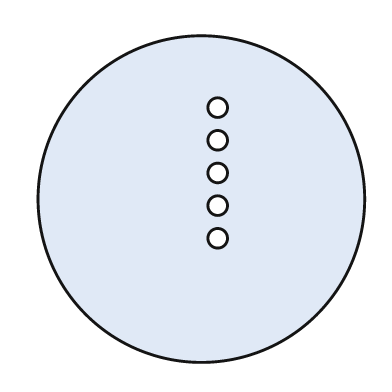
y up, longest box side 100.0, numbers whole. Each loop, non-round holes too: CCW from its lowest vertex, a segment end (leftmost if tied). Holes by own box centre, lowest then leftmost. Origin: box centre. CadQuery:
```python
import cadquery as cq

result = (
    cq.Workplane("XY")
    .moveTo(0.0, 0.0)
    .circle(50.0)
    .moveTo(5.0, -12.0)
    .circle(3.0)
    .moveTo(5.0, -2.0)
    .circle(3.0)
    .moveTo(5.0, 8.0)
    .circle(3.0)
    .moveTo(5.0, 18.0)
    .circle(3.0)
    .moveTo(5.0, 28.0)
    .circle(3.0)
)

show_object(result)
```